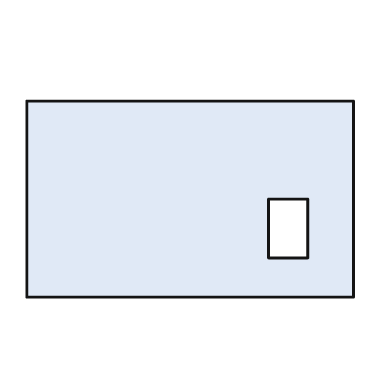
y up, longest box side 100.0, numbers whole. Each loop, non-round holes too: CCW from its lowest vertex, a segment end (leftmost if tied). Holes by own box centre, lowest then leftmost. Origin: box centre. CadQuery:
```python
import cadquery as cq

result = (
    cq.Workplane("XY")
    .moveTo(-50.0, -30.0)
    .lineTo(50.0, -30.0)
    .lineTo(50.0, 30.0)
    .lineTo(-50.0, 30.0)
    .close()
    .moveTo(24.0, -18.0)
    .lineTo(36.0, -18.0)
    .lineTo(36.0, 0.0)
    .lineTo(24.0, 0.0)
    .close()
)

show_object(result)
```